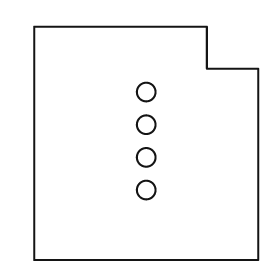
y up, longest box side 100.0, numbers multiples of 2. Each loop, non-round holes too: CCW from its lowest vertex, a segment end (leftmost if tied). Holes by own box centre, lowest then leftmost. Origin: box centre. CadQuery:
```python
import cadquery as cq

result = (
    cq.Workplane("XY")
    .moveTo(-48.0, -50.0)
    .lineTo(48.0, -50.0)
    .lineTo(48.0, 32.0)
    .lineTo(26.0, 32.0)
    .lineTo(26.0, 50.0)
    .lineTo(-48.0, 50.0)
    .close()
    .moveTo(0.0, -20.0)
    .circle(4.0)
    .moveTo(0.0, -6.0)
    .circle(4.0)
    .moveTo(0.0, 8.0)
    .circle(4.0)
    .moveTo(0.0, 22.0)
    .circle(4.0)
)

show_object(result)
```